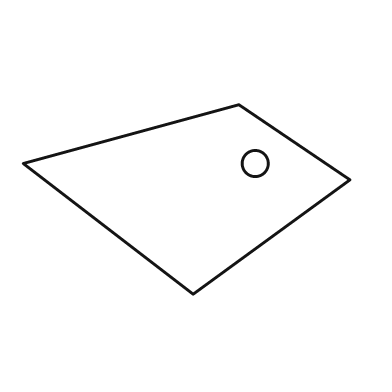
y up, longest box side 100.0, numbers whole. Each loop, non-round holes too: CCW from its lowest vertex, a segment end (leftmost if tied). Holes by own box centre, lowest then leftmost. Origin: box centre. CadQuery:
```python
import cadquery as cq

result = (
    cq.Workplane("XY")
    .moveTo(2.0, -29.0)
    .lineTo(50.0, 6.0)
    .lineTo(16.0, 29.0)
    .lineTo(-50.0, 11.0)
    .close()
    .moveTo(21.0, 11.0)
    .circle(4.0)
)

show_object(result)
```